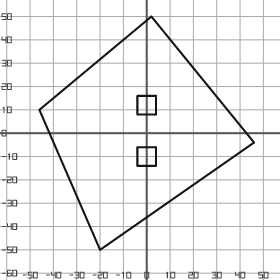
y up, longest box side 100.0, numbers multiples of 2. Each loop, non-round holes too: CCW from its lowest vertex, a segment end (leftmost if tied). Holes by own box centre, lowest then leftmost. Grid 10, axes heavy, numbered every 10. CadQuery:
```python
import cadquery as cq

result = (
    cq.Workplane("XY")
    .moveTo(-20.0, -50.0)
    .lineTo(46.0, -4.0)
    .lineTo(2.0, 50.0)
    .lineTo(-46.0, 10.0)
    .close()
    .moveTo(-4.0, -14.0)
    .lineTo(4.0, -14.0)
    .lineTo(4.0, -6.0)
    .lineTo(-4.0, -6.0)
    .close()
    .moveTo(-4.0, 8.0)
    .lineTo(4.0, 8.0)
    .lineTo(4.0, 16.0)
    .lineTo(-4.0, 16.0)
    .close()
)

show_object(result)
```